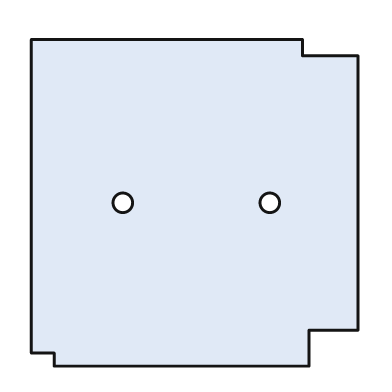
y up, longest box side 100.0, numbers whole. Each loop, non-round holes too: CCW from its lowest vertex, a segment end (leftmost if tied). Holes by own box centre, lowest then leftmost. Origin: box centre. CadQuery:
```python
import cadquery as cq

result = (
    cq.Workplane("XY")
    .moveTo(-43.0, -50.0)
    .lineTo(35.0, -50.0)
    .lineTo(35.0, -39.0)
    .lineTo(50.0, -39.0)
    .lineTo(50.0, 45.0)
    .lineTo(33.0, 45.0)
    .lineTo(33.0, 50.0)
    .lineTo(-50.0, 50.0)
    .lineTo(-50.0, -46.0)
    .lineTo(-43.0, -46.0)
    .close()
    .moveTo(-22.0, 0.0)
    .circle(3.0)
    .moveTo(23.0, 0.0)
    .circle(3.0)
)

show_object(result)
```